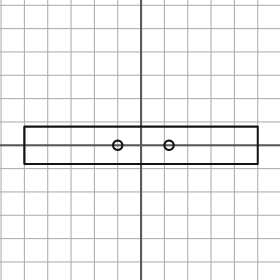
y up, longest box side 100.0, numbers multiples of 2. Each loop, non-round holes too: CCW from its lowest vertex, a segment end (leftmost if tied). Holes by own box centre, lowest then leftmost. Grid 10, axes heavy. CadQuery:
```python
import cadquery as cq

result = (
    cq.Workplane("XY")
    .moveTo(-50.0, -8.0)
    .lineTo(50.0, -8.0)
    .lineTo(50.0, 8.0)
    .lineTo(-50.0, 8.0)
    .close()
    .moveTo(-10.0, 0.0)
    .circle(2.0)
    .moveTo(12.0, 0.0)
    .circle(2.0)
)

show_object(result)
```